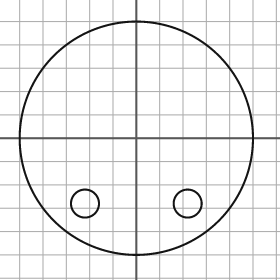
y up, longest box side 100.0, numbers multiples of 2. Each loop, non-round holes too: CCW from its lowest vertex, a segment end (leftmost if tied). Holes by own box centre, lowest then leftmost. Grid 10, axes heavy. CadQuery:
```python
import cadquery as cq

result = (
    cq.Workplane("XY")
    .moveTo(0.0, 0.0)
    .circle(50.0)
    .moveTo(-22.0, -28.0)
    .circle(6.0)
    .moveTo(22.0, -28.0)
    .circle(6.0)
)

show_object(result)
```